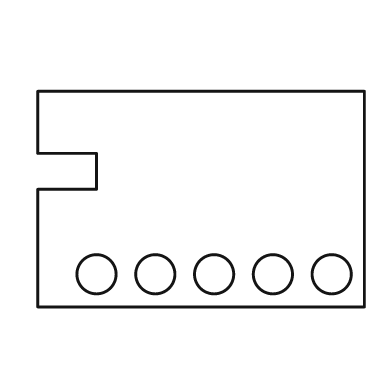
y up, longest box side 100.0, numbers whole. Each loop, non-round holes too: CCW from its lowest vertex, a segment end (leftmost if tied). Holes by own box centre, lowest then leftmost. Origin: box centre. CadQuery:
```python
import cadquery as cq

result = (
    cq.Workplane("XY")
    .moveTo(-50.0, -33.0)
    .lineTo(50.0, -33.0)
    .lineTo(50.0, 33.0)
    .lineTo(-50.0, 33.0)
    .lineTo(-50.0, 14.0)
    .lineTo(-32.0, 14.0)
    .lineTo(-32.0, 3.0)
    .lineTo(-50.0, 3.0)
    .close()
    .moveTo(-32.0, -23.0)
    .circle(6.0)
    .moveTo(-14.0, -23.0)
    .circle(6.0)
    .moveTo(4.0, -23.0)
    .circle(6.0)
    .moveTo(22.0, -23.0)
    .circle(6.0)
    .moveTo(40.0, -23.0)
    .circle(6.0)
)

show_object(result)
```